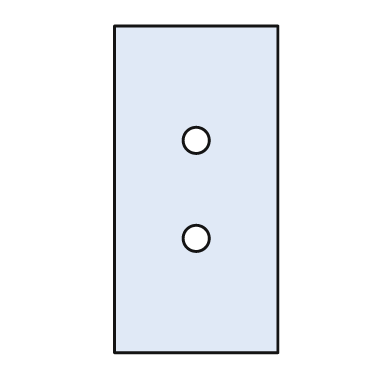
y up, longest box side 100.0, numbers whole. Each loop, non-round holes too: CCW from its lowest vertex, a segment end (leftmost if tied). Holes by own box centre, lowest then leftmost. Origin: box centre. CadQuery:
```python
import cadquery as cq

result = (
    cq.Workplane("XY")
    .moveTo(-25.0, -50.0)
    .lineTo(25.0, -50.0)
    .lineTo(25.0, 50.0)
    .lineTo(-25.0, 50.0)
    .close()
    .moveTo(0.0, -15.0)
    .circle(4.0)
    .moveTo(0.0, 15.0)
    .circle(4.0)
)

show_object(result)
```